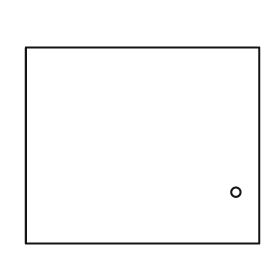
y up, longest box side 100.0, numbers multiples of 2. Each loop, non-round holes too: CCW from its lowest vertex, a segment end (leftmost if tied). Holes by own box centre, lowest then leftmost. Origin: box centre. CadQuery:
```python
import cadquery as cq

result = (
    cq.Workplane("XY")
    .moveTo(-50.0, -42.0)
    .lineTo(50.0, -42.0)
    .lineTo(50.0, 42.0)
    .lineTo(-50.0, 42.0)
    .close()
    .moveTo(40.0, -20.0)
    .circle(2.0)
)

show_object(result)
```